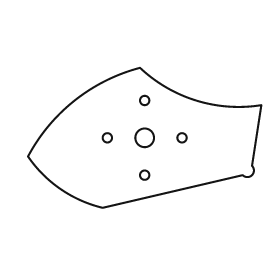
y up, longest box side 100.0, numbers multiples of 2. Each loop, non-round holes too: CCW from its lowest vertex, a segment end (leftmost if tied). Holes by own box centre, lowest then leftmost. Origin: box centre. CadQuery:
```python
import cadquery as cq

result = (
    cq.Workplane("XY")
    .moveTo(-18.0, -30.0)
    .lineTo(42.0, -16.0)
    .threePointArc((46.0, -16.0), (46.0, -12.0))
    .lineTo(50.0, 14.0)
    .threePointArc((22.0, 16.0), (-2.0, 30.0))
    .threePointArc((-30.0, 16.0), (-50.0, -8.0))
    .threePointArc((-36.0, -22.0), (-18.0, -30.0))
    .close()
    .moveTo(0.0, -16.0)
    .circle(2.0)
    .moveTo(-16.0, 0.0)
    .circle(2.0)
    .moveTo(0.0, 0.0)
    .circle(4.0)
    .moveTo(16.0, 0.0)
    .circle(2.0)
    .moveTo(0.0, 16.0)
    .circle(2.0)
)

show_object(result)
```